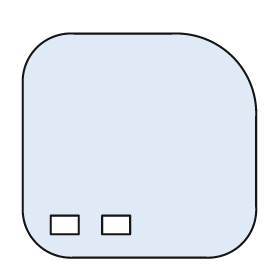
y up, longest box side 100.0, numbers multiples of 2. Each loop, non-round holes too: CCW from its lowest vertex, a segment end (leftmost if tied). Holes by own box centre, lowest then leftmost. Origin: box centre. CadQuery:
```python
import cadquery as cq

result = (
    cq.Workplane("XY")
    .moveTo(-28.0, -48.0)
    .lineTo(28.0, -48.0)
    .threePointArc((44.0, -42.0), (50.0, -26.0))
    .lineTo(50.0, 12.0)
    .threePointArc((40.0, 38.0), (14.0, 48.0))
    .lineTo(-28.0, 48.0)
    .threePointArc((-44.0, 42.0), (-50.0, 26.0))
    .lineTo(-50.0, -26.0)
    .threePointArc((-44.0, -42.0), (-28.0, -48.0))
    .close()
    .moveTo(-38.0, -38.0)
    .lineTo(-26.0, -38.0)
    .lineTo(-26.0, -30.0)
    .lineTo(-38.0, -30.0)
    .close()
    .moveTo(-16.0, -38.0)
    .lineTo(-4.0, -38.0)
    .lineTo(-4.0, -30.0)
    .lineTo(-16.0, -30.0)
    .close()
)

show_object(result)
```